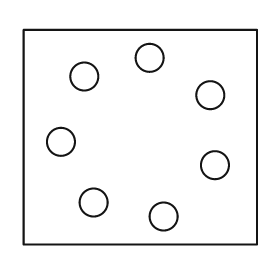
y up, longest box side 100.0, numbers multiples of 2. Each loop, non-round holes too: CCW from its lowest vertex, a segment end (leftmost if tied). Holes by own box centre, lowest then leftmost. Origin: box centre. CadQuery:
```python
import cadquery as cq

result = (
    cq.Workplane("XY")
    .moveTo(-50.0, -46.0)
    .lineTo(50.0, -46.0)
    .lineTo(50.0, 46.0)
    .lineTo(-50.0, 46.0)
    .close()
    .moveTo(10.0, -34.0)
    .circle(6.0)
    .moveTo(-20.0, -28.0)
    .circle(6.0)
    .moveTo(32.0, -12.0)
    .circle(6.0)
    .moveTo(-34.0, -2.0)
    .circle(6.0)
    .moveTo(30.0, 18.0)
    .circle(6.0)
    .moveTo(-24.0, 26.0)
    .circle(6.0)
    .moveTo(4.0, 34.0)
    .circle(6.0)
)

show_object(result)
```